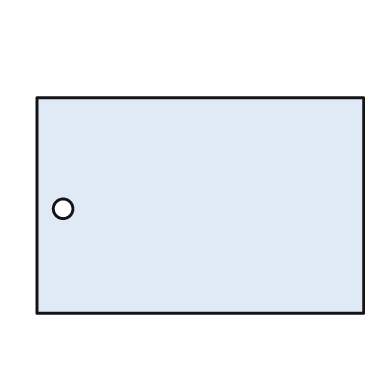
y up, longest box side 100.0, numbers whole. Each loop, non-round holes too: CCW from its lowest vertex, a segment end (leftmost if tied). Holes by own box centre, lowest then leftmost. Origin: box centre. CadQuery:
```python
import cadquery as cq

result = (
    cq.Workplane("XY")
    .moveTo(-50.0, -33.0)
    .lineTo(50.0, -33.0)
    .lineTo(50.0, 33.0)
    .lineTo(-50.0, 33.0)
    .close()
    .moveTo(-42.0, -1.0)
    .circle(3.0)
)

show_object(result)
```